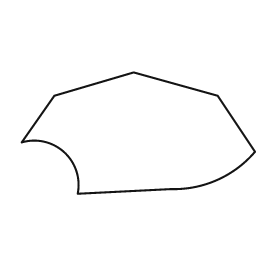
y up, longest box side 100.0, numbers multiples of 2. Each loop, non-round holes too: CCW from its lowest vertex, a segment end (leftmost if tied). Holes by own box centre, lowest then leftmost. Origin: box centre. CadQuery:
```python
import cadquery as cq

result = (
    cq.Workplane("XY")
    .moveTo(-26.0, -26.0)
    .lineTo(14.0, -24.0)
    .threePointArc((34.0, -20.0), (50.0, -8.0))
    .lineTo(34.0, 16.0)
    .lineTo(-2.0, 26.0)
    .lineTo(-36.0, 16.0)
    .lineTo(-50.0, -4.0)
    .threePointArc((-32.0, -8.0), (-26.0, -26.0))
    .close()
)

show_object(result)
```